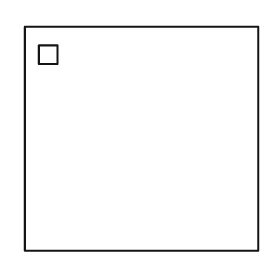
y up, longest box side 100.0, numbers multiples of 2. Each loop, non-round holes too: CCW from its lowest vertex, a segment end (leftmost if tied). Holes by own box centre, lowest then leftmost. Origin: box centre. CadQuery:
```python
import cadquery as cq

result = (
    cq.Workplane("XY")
    .moveTo(-50.0, -48.0)
    .lineTo(50.0, -48.0)
    .lineTo(50.0, 48.0)
    .lineTo(-50.0, 48.0)
    .close()
    .moveTo(-44.0, 32.0)
    .lineTo(-36.0, 32.0)
    .lineTo(-36.0, 40.0)
    .lineTo(-44.0, 40.0)
    .close()
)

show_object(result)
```